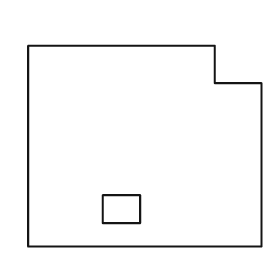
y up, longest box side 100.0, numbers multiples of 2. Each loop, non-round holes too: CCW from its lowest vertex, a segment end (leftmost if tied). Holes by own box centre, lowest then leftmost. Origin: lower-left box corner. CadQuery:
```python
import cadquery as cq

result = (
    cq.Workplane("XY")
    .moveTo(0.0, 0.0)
    .lineTo(100.0, 0.0)
    .lineTo(100.0, 70.0)
    .lineTo(80.0, 70.0)
    .lineTo(80.0, 86.0)
    .lineTo(0.0, 86.0)
    .close()
    .moveTo(32.0, 10.0)
    .lineTo(48.0, 10.0)
    .lineTo(48.0, 22.0)
    .lineTo(32.0, 22.0)
    .close()
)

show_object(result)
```